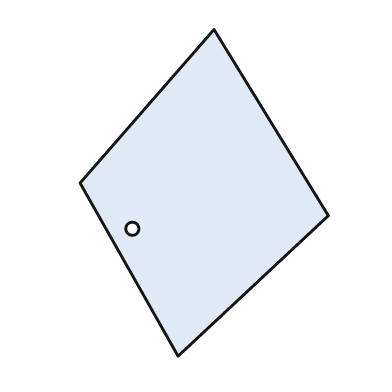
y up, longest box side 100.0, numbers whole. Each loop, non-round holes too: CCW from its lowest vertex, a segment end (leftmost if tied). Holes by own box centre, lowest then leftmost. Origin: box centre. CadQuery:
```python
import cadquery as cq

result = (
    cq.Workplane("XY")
    .moveTo(-8.0, -50.0)
    .lineTo(38.0, -7.0)
    .lineTo(3.0, 50.0)
    .lineTo(-38.0, 3.0)
    .close()
    .moveTo(-22.0, -11.0)
    .circle(2.0)
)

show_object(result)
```